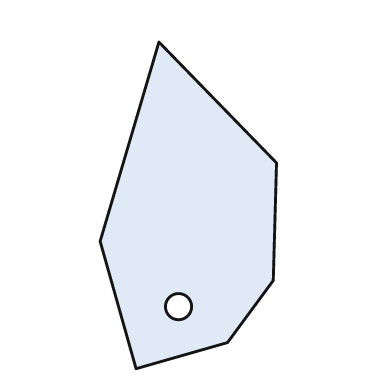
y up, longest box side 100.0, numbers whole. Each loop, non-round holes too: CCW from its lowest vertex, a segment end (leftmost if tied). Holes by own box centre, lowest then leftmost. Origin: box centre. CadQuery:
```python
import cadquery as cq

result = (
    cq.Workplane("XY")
    .moveTo(-16.0, -50.0)
    .lineTo(12.0, -42.0)
    .lineTo(26.0, -23.0)
    .lineTo(27.0, 13.0)
    .lineTo(-9.0, 50.0)
    .lineTo(-27.0, -11.0)
    .close()
    .moveTo(-3.0, -31.0)
    .circle(4.0)
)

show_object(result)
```